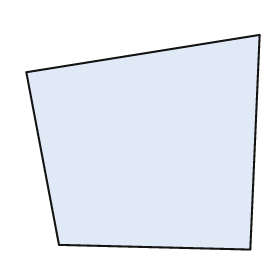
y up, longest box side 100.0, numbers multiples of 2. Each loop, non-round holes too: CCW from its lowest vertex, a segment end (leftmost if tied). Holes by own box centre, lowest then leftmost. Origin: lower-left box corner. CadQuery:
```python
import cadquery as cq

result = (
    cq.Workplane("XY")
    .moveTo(96.0, 0.0)
    .lineTo(100.0, 92.0)
    .lineTo(0.0, 76.0)
    .lineTo(14.0, 2.0)
    .close()
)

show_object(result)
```